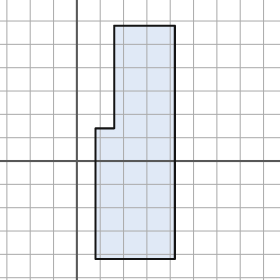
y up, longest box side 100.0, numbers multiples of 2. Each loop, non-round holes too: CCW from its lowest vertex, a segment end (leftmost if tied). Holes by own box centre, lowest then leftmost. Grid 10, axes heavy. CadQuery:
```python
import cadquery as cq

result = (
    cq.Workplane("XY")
    .moveTo(8.0, -42.0)
    .lineTo(42.0, -42.0)
    .lineTo(42.0, 58.0)
    .lineTo(16.0, 58.0)
    .lineTo(16.0, 14.0)
    .lineTo(8.0, 14.0)
    .close()
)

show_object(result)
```